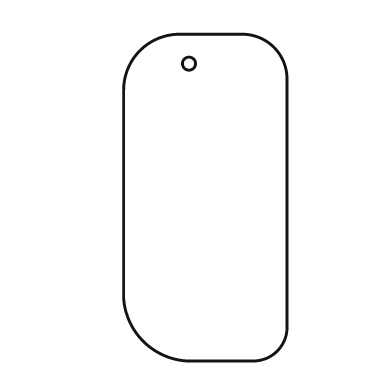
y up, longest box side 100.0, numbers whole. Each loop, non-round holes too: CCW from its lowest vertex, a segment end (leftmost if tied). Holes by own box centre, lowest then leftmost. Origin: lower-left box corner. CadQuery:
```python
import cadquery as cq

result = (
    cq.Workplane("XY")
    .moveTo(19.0, 0.0)
    .lineTo(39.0, 0.0)
    .threePointArc((47.0, 3.0), (50.0, 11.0))
    .lineTo(50.0, 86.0)
    .threePointArc((46.0, 96.0), (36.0, 100.0))
    .lineTo(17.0, 100.0)
    .threePointArc((5.0, 95.0), (0.0, 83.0))
    .lineTo(0.0, 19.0)
    .threePointArc((6.0, 6.0), (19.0, 0.0))
    .close()
    .moveTo(20.0, 91.0)
    .circle(2.0)
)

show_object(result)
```